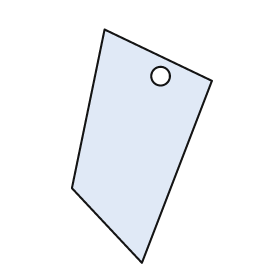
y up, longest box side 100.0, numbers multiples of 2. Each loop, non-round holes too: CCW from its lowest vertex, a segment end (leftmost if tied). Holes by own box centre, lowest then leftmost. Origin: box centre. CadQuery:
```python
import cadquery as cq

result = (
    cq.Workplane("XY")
    .moveTo(0.0, -50.0)
    .lineTo(30.0, 28.0)
    .lineTo(-16.0, 50.0)
    .lineTo(-30.0, -18.0)
    .close()
    .moveTo(8.0, 30.0)
    .circle(4.0)
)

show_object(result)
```